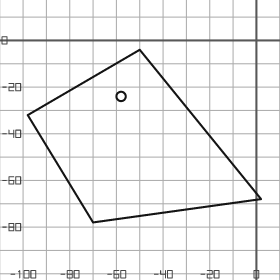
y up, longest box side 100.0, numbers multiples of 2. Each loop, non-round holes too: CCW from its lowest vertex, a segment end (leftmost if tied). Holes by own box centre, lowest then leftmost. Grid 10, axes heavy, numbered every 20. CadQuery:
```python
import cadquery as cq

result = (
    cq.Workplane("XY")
    .moveTo(-70.0, -78.0)
    .lineTo(2.0, -68.0)
    .lineTo(-50.0, -4.0)
    .lineTo(-98.0, -32.0)
    .close()
    .moveTo(-58.0, -24.0)
    .circle(2.0)
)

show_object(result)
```